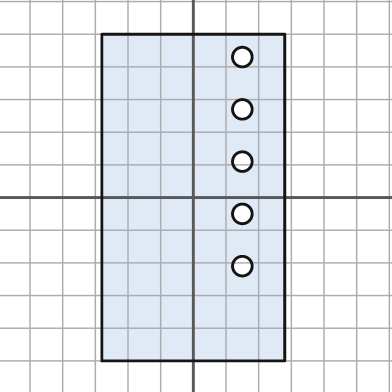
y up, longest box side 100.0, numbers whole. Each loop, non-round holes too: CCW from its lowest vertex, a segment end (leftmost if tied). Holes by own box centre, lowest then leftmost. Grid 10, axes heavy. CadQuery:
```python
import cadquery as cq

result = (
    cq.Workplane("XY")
    .moveTo(-28.0, -50.0)
    .lineTo(28.0, -50.0)
    .lineTo(28.0, 50.0)
    .lineTo(-28.0, 50.0)
    .close()
    .moveTo(15.0, -21.0)
    .circle(3.0)
    .moveTo(15.0, -5.0)
    .circle(3.0)
    .moveTo(15.0, 11.0)
    .circle(3.0)
    .moveTo(15.0, 27.0)
    .circle(3.0)
    .moveTo(15.0, 43.0)
    .circle(3.0)
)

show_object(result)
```